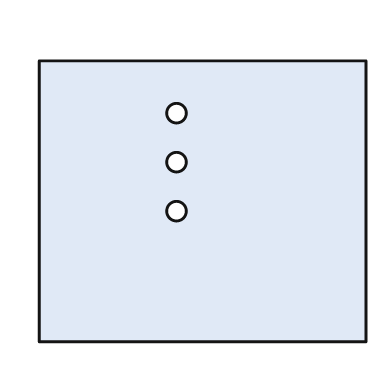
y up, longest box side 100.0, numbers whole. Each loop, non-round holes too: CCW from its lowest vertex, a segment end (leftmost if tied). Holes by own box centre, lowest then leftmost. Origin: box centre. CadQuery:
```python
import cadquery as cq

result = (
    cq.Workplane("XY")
    .moveTo(-50.0, -43.0)
    .lineTo(50.0, -43.0)
    .lineTo(50.0, 43.0)
    .lineTo(-50.0, 43.0)
    .close()
    .moveTo(-8.0, -3.0)
    .circle(3.0)
    .moveTo(-8.0, 12.0)
    .circle(3.0)
    .moveTo(-8.0, 27.0)
    .circle(3.0)
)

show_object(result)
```